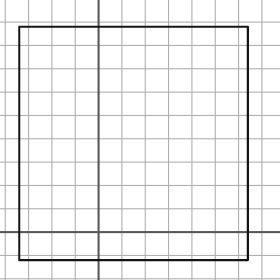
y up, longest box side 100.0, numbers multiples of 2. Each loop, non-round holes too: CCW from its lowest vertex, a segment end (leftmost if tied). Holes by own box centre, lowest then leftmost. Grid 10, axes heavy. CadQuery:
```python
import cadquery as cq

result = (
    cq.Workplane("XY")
    .moveTo(-34.0, -12.0)
    .lineTo(64.0, -12.0)
    .lineTo(64.0, 88.0)
    .lineTo(-34.0, 88.0)
    .close()
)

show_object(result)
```